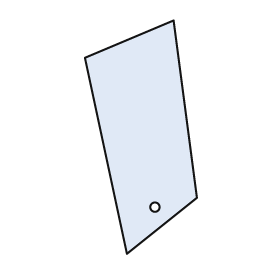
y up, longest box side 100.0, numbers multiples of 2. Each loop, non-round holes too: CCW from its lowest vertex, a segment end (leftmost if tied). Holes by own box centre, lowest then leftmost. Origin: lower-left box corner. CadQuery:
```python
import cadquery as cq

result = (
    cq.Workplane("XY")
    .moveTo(18.0, 0.0)
    .lineTo(48.0, 24.0)
    .lineTo(38.0, 100.0)
    .lineTo(0.0, 84.0)
    .close()
    .moveTo(30.0, 20.0)
    .circle(2.0)
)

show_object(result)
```